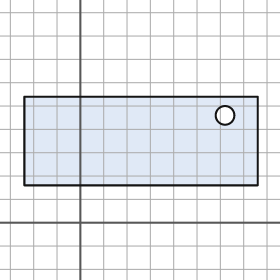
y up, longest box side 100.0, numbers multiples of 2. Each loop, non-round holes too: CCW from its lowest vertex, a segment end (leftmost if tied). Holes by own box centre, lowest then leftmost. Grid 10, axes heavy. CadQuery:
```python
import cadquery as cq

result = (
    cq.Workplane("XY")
    .moveTo(-24.0, 16.0)
    .lineTo(76.0, 16.0)
    .lineTo(76.0, 54.0)
    .lineTo(-24.0, 54.0)
    .close()
    .moveTo(62.0, 46.0)
    .circle(4.0)
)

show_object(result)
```